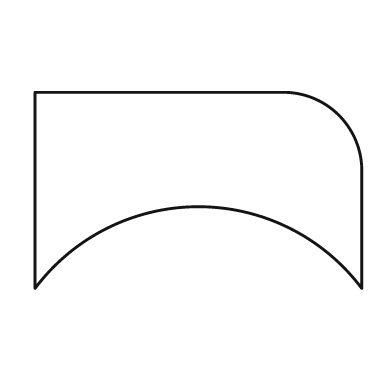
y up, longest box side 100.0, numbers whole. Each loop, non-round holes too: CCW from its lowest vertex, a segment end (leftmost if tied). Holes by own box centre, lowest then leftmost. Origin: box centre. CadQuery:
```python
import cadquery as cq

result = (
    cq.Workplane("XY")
    .moveTo(-50.0, -30.0)
    .threePointArc((0.0, -5.0), (50.0, -30.0))
    .lineTo(50.0, 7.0)
    .threePointArc((43.0, 23.0), (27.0, 30.0))
    .lineTo(-50.0, 30.0)
    .close()
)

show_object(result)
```